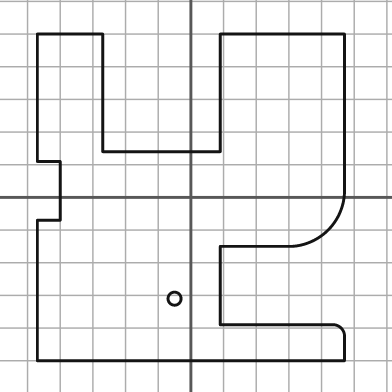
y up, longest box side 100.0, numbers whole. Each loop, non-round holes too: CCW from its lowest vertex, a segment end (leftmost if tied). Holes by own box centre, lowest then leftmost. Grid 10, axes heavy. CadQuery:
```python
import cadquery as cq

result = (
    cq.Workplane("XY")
    .moveTo(-47.0, -50.0)
    .lineTo(47.0, -50.0)
    .lineTo(47.0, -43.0)
    .threePointArc((46.0, -40.0), (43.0, -39.0))
    .lineTo(9.0, -39.0)
    .lineTo(9.0, -15.0)
    .lineTo(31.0, -15.0)
    .threePointArc((42.0, -10.0), (47.0, 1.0))
    .lineTo(47.0, 50.0)
    .lineTo(9.0, 50.0)
    .lineTo(9.0, 14.0)
    .lineTo(-27.0, 14.0)
    .lineTo(-27.0, 50.0)
    .lineTo(-47.0, 50.0)
    .lineTo(-47.0, 11.0)
    .lineTo(-40.0, 11.0)
    .lineTo(-40.0, -7.0)
    .lineTo(-47.0, -7.0)
    .close()
    .moveTo(-5.0, -31.0)
    .circle(2.0)
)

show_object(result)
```